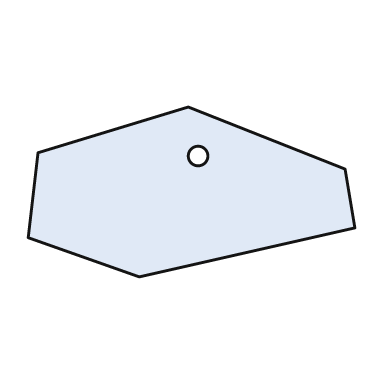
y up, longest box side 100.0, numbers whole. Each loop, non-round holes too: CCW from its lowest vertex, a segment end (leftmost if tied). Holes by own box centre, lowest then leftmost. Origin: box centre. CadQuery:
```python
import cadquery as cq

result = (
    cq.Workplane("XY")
    .moveTo(-16.0, -26.0)
    .lineTo(50.0, -11.0)
    .lineTo(47.0, 7.0)
    .lineTo(-1.0, 26.0)
    .lineTo(-47.0, 12.0)
    .lineTo(-50.0, -14.0)
    .close()
    .moveTo(2.0, 11.0)
    .circle(3.0)
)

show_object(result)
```